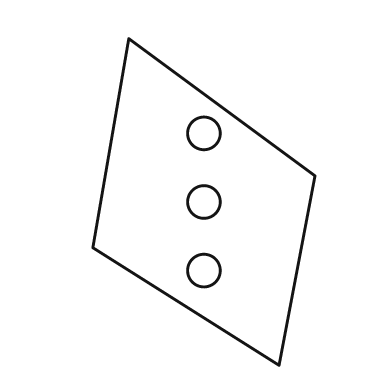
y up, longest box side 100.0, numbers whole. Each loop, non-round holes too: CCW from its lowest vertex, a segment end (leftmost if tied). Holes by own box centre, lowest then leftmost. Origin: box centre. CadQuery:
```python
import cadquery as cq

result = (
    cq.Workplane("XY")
    .moveTo(23.0, -50.0)
    .lineTo(34.0, 8.0)
    .lineTo(-23.0, 50.0)
    .lineTo(-34.0, -14.0)
    .close()
    .moveTo(0.0, -21.0)
    .circle(5.0)
    .moveTo(0.0, 0.0)
    .circle(5.0)
    .moveTo(0.0, 21.0)
    .circle(5.0)
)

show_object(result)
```